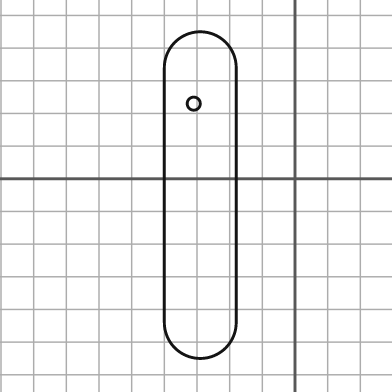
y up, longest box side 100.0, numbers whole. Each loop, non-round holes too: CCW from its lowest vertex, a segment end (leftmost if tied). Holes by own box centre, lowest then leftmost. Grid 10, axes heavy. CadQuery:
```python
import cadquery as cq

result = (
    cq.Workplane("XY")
    .moveTo(-40.0, -44.0)
    .threePointArc((-29.0, -55.0), (-18.0, -44.0))
    .lineTo(-18.0, 34.0)
    .threePointArc((-29.0, 45.0), (-40.0, 34.0))
    .close()
    .moveTo(-31.0, 23.0)
    .circle(2.0)
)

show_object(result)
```